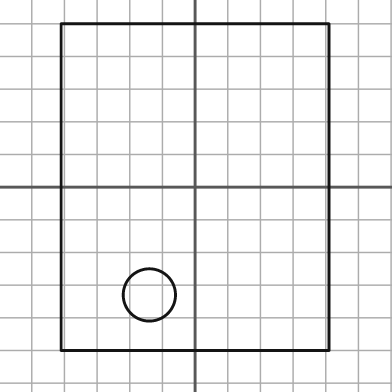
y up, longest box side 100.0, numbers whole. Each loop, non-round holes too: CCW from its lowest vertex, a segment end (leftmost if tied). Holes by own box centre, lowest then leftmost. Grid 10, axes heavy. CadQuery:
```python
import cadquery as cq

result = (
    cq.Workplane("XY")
    .moveTo(-41.0, -50.0)
    .lineTo(41.0, -50.0)
    .lineTo(41.0, 50.0)
    .lineTo(-41.0, 50.0)
    .close()
    .moveTo(-14.0, -33.0)
    .circle(8.0)
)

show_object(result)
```